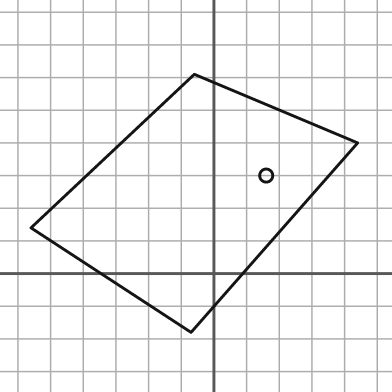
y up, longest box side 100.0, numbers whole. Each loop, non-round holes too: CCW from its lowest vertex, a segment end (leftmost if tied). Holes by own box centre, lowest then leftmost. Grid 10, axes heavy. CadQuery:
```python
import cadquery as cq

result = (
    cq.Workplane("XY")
    .moveTo(-7.0, -18.0)
    .lineTo(44.0, 40.0)
    .lineTo(-6.0, 61.0)
    .lineTo(-56.0, 14.0)
    .close()
    .moveTo(16.0, 30.0)
    .circle(2.0)
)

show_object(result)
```